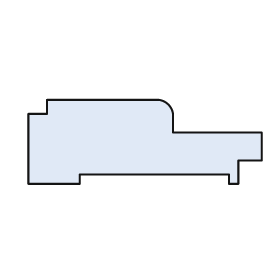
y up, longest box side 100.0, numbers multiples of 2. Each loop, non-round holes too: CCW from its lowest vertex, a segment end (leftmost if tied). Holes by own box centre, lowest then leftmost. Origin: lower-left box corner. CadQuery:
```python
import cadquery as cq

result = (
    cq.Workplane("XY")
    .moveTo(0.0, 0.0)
    .lineTo(22.0, 0.0)
    .lineTo(22.0, 4.0)
    .lineTo(86.0, 4.0)
    .lineTo(86.0, 0.0)
    .lineTo(90.0, 0.0)
    .lineTo(90.0, 10.0)
    .lineTo(100.0, 10.0)
    .lineTo(100.0, 22.0)
    .lineTo(62.0, 22.0)
    .lineTo(62.0, 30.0)
    .threePointArc((60.0, 34.0), (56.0, 36.0))
    .lineTo(8.0, 36.0)
    .lineTo(8.0, 30.0)
    .lineTo(0.0, 30.0)
    .close()
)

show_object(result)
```